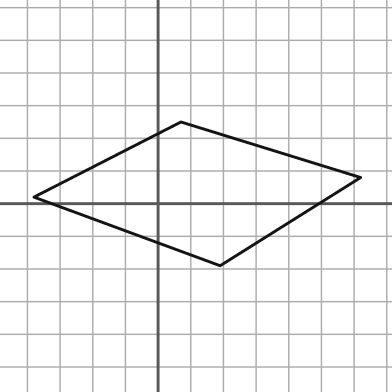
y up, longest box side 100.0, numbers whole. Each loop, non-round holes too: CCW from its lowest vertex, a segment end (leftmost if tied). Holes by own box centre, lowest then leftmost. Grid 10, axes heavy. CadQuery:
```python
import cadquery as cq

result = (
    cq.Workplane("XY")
    .moveTo(19.0, -19.0)
    .lineTo(62.0, 8.0)
    .lineTo(7.0, 25.0)
    .lineTo(-38.0, 2.0)
    .close()
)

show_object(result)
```